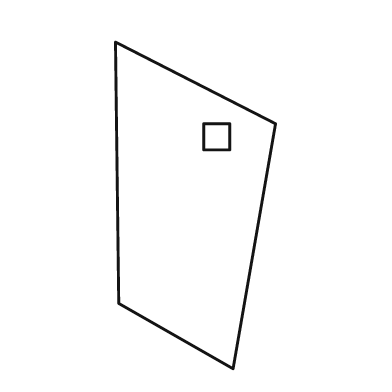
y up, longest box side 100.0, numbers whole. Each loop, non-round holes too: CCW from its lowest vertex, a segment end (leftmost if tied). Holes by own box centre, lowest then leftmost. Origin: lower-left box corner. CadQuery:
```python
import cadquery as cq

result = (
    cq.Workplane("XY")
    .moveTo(36.0, 0.0)
    .lineTo(49.0, 75.0)
    .lineTo(0.0, 100.0)
    .lineTo(1.0, 20.0)
    .close()
    .moveTo(27.0, 67.0)
    .lineTo(35.0, 67.0)
    .lineTo(35.0, 75.0)
    .lineTo(27.0, 75.0)
    .close()
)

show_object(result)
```